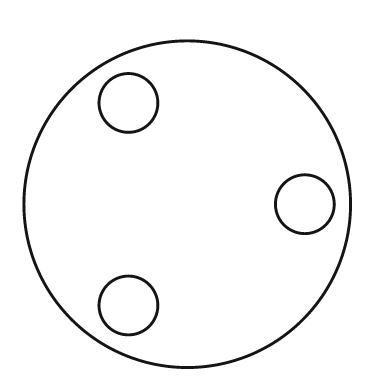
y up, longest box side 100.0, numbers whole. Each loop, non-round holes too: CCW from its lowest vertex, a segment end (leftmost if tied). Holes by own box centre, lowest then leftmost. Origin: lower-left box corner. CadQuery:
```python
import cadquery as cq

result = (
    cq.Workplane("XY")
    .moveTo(50.0, 50.0)
    .circle(50.0)
    .moveTo(32.0, 19.0)
    .circle(9.0)
    .moveTo(86.0, 50.0)
    .circle(9.0)
    .moveTo(32.0, 81.0)
    .circle(9.0)
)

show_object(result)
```